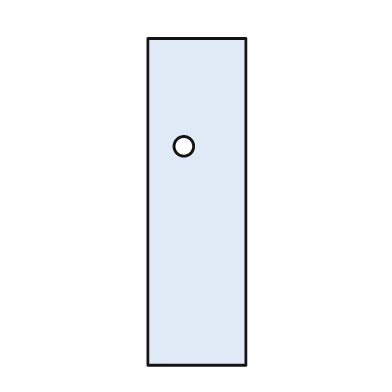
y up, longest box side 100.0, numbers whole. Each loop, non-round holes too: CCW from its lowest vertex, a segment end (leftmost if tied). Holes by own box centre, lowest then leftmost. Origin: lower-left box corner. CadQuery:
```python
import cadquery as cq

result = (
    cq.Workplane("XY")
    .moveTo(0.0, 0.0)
    .lineTo(30.0, 0.0)
    .lineTo(30.0, 100.0)
    .lineTo(0.0, 100.0)
    .close()
    .moveTo(11.0, 67.0)
    .circle(3.0)
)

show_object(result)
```